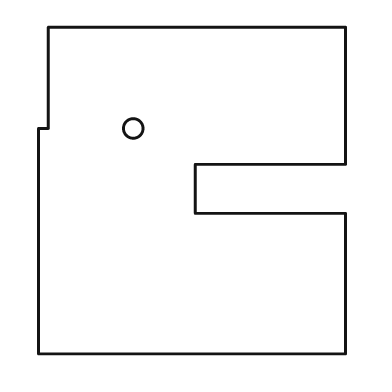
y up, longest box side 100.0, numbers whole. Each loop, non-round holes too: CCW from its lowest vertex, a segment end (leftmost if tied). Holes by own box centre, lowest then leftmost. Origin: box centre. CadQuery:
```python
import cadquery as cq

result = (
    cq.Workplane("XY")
    .moveTo(-47.0, -50.0)
    .lineTo(47.0, -50.0)
    .lineTo(47.0, -7.0)
    .lineTo(1.0, -7.0)
    .lineTo(1.0, 8.0)
    .lineTo(47.0, 8.0)
    .lineTo(47.0, 50.0)
    .lineTo(-44.0, 50.0)
    .lineTo(-44.0, 19.0)
    .lineTo(-47.0, 19.0)
    .close()
    .moveTo(-18.0, 19.0)
    .circle(3.0)
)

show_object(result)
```